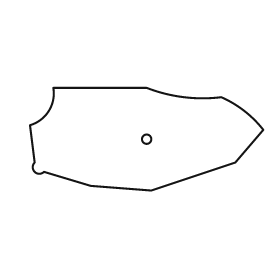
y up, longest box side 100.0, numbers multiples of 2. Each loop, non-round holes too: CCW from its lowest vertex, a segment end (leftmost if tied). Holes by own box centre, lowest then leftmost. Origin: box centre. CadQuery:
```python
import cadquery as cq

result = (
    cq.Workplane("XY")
    .moveTo(2.0, -22.0)
    .lineTo(38.0, -10.0)
    .lineTo(50.0, 4.0)
    .threePointArc((42.0, 12.0), (32.0, 18.0))
    .threePointArc((16.0, 18.0), (0.0, 22.0))
    .lineTo(-40.0, 22.0)
    .threePointArc((-42.0, 12.0), (-50.0, 6.0))
    .lineTo(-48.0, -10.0)
    .threePointArc((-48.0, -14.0), (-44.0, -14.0))
    .lineTo(-24.0, -20.0)
    .close()
    .moveTo(0.0, 0.0)
    .circle(2.0)
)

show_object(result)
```